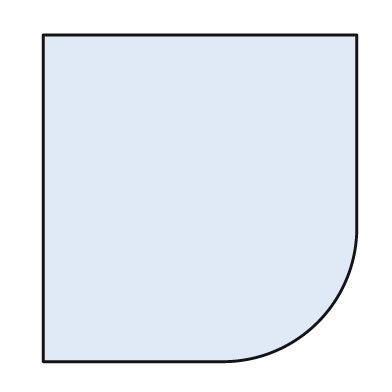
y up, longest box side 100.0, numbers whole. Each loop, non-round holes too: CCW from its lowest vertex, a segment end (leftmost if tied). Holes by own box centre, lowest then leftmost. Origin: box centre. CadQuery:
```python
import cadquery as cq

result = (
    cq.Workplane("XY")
    .moveTo(-48.0, -50.0)
    .lineTo(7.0, -50.0)
    .threePointArc((36.0, -38.0), (48.0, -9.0))
    .lineTo(48.0, 50.0)
    .lineTo(-48.0, 50.0)
    .close()
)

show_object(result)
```